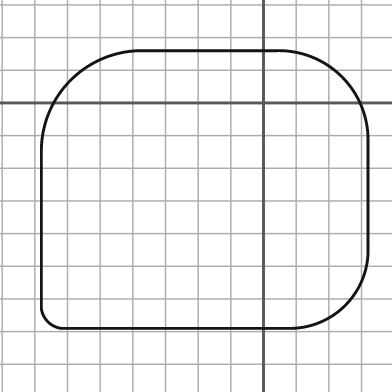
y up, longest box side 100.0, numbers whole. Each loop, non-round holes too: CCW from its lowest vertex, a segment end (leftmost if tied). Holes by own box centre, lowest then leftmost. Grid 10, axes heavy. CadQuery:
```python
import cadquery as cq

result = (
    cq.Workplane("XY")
    .moveTo(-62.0, -69.0)
    .lineTo(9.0, -69.0)
    .threePointArc((25.0, -62.0), (32.0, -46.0))
    .lineTo(32.0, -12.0)
    .threePointArc((24.0, 8.0), (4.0, 16.0))
    .lineTo(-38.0, 16.0)
    .threePointArc((-59.0, 7.0), (-68.0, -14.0))
    .lineTo(-68.0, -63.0)
    .threePointArc((-66.0, -67.0), (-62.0, -69.0))
    .close()
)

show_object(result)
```